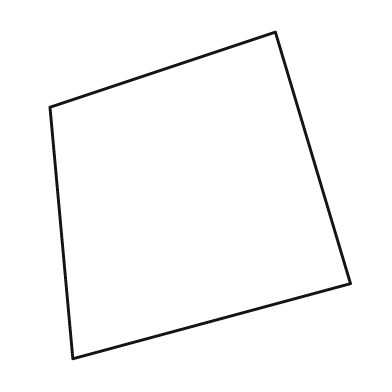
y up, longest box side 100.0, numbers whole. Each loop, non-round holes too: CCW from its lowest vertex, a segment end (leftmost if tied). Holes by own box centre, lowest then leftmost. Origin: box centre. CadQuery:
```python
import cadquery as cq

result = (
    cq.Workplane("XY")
    .moveTo(-39.0, -50.0)
    .lineTo(46.0, -27.0)
    .lineTo(23.0, 50.0)
    .lineTo(-46.0, 27.0)
    .close()
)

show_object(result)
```